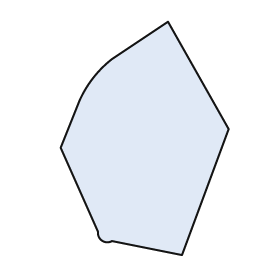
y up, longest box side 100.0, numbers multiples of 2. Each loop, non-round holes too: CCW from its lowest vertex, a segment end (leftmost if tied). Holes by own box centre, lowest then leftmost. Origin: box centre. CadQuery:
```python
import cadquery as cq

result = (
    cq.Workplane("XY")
    .moveTo(16.0, -50.0)
    .lineTo(36.0, 4.0)
    .lineTo(10.0, 50.0)
    .lineTo(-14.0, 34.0)
    .threePointArc((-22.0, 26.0), (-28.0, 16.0))
    .lineTo(-36.0, -4.0)
    .lineTo(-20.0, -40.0)
    .threePointArc((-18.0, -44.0), (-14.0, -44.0))
    .close()
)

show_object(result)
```